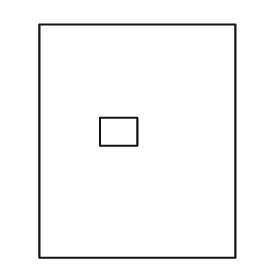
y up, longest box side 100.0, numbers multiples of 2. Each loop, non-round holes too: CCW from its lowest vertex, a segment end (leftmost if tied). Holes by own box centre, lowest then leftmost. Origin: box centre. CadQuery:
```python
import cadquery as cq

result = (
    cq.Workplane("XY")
    .moveTo(-42.0, -50.0)
    .lineTo(42.0, -50.0)
    .lineTo(42.0, 50.0)
    .lineTo(-42.0, 50.0)
    .close()
    .moveTo(-16.0, -2.0)
    .lineTo(0.0, -2.0)
    .lineTo(0.0, 10.0)
    .lineTo(-16.0, 10.0)
    .close()
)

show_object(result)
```